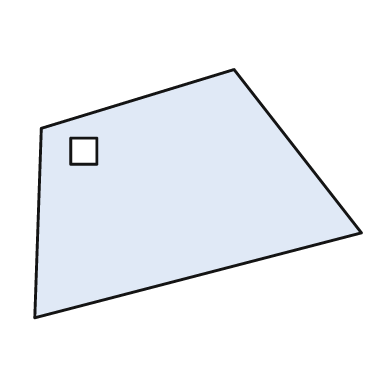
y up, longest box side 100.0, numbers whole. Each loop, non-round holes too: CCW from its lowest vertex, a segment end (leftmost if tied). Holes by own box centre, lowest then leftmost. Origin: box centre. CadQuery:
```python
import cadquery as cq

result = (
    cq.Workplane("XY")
    .moveTo(-50.0, -38.0)
    .lineTo(50.0, -12.0)
    .lineTo(11.0, 38.0)
    .lineTo(-48.0, 20.0)
    .close()
    .moveTo(-39.0, 9.0)
    .lineTo(-31.0, 9.0)
    .lineTo(-31.0, 17.0)
    .lineTo(-39.0, 17.0)
    .close()
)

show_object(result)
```